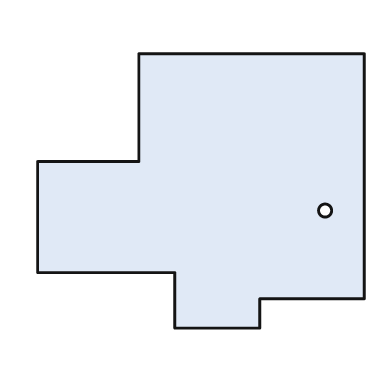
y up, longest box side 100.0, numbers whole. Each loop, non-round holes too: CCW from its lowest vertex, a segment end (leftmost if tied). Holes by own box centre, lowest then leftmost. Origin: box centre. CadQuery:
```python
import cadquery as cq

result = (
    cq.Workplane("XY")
    .moveTo(-8.0, -42.0)
    .lineTo(18.0, -42.0)
    .lineTo(18.0, -33.0)
    .lineTo(50.0, -33.0)
    .lineTo(50.0, 42.0)
    .lineTo(-19.0, 42.0)
    .lineTo(-19.0, 9.0)
    .lineTo(-50.0, 9.0)
    .lineTo(-50.0, -25.0)
    .lineTo(-8.0, -25.0)
    .close()
    .moveTo(38.0, -6.0)
    .circle(2.0)
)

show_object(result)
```